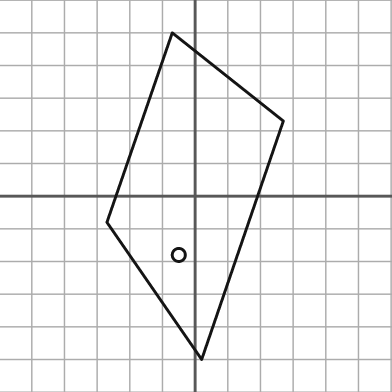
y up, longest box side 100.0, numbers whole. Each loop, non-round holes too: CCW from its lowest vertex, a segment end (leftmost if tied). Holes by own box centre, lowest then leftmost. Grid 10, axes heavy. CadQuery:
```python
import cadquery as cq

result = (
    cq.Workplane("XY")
    .moveTo(2.0, -50.0)
    .lineTo(27.0, 23.0)
    .lineTo(-7.0, 50.0)
    .lineTo(-27.0, -8.0)
    .close()
    .moveTo(-5.0, -18.0)
    .circle(2.0)
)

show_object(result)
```